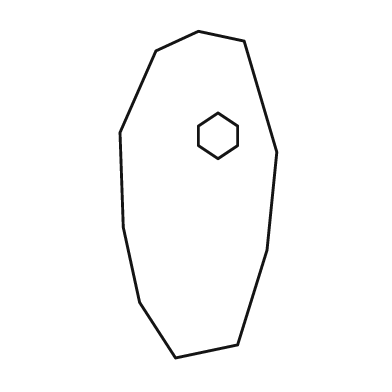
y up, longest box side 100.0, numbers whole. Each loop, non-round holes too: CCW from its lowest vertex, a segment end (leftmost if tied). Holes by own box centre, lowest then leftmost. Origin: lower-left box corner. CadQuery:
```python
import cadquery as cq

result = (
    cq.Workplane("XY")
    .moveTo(17.0, 0.0)
    .lineTo(36.0, 4.0)
    .lineTo(45.0, 33.0)
    .lineTo(48.0, 63.0)
    .lineTo(38.0, 97.0)
    .lineTo(24.0, 100.0)
    .lineTo(11.0, 94.0)
    .lineTo(0.0, 69.0)
    .lineTo(1.0, 40.0)
    .lineTo(6.0, 17.0)
    .close()
    .moveTo(30.0, 61.0)
    .lineTo(36.0, 65.0)
    .lineTo(36.0, 71.0)
    .lineTo(30.0, 75.0)
    .lineTo(24.0, 71.0)
    .lineTo(24.0, 65.0)
    .close()
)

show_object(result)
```